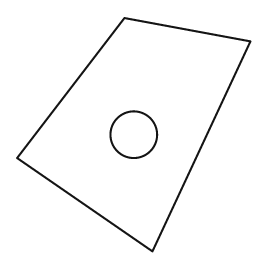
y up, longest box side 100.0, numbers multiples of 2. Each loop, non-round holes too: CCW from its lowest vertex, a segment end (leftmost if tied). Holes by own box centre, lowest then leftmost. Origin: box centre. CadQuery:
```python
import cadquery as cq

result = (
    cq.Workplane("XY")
    .moveTo(8.0, -50.0)
    .lineTo(50.0, 40.0)
    .lineTo(-4.0, 50.0)
    .lineTo(-50.0, -10.0)
    .close()
    .moveTo(0.0, 0.0)
    .circle(10.0)
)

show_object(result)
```